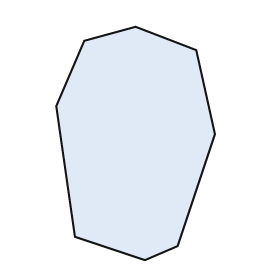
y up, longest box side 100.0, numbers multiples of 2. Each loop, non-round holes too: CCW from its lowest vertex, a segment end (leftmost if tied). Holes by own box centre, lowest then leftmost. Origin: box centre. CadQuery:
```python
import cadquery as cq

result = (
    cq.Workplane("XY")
    .moveTo(4.0, -50.0)
    .lineTo(18.0, -44.0)
    .lineTo(34.0, 4.0)
    .lineTo(26.0, 40.0)
    .lineTo(0.0, 50.0)
    .lineTo(-22.0, 44.0)
    .lineTo(-34.0, 16.0)
    .lineTo(-26.0, -40.0)
    .close()
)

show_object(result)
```